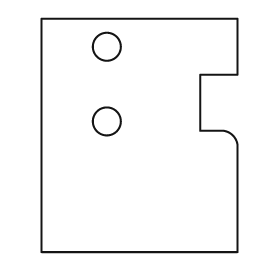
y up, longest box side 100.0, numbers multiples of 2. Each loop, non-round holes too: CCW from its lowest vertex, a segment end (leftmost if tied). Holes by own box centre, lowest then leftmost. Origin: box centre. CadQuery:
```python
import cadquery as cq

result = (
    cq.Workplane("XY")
    .moveTo(-42.0, -50.0)
    .lineTo(42.0, -50.0)
    .lineTo(42.0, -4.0)
    .threePointArc((40.0, 0.0), (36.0, 2.0))
    .lineTo(26.0, 2.0)
    .lineTo(26.0, 26.0)
    .lineTo(42.0, 26.0)
    .lineTo(42.0, 50.0)
    .lineTo(-42.0, 50.0)
    .close()
    .moveTo(-14.0, 6.0)
    .circle(6.0)
    .moveTo(-14.0, 38.0)
    .circle(6.0)
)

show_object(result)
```